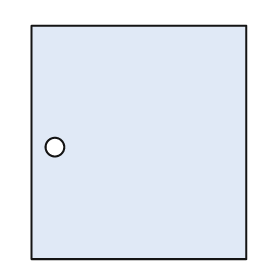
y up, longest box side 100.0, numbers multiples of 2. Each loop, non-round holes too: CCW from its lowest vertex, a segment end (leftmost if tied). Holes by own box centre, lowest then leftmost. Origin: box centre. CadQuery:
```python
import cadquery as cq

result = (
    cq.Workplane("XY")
    .moveTo(-46.0, -50.0)
    .lineTo(46.0, -50.0)
    .lineTo(46.0, 50.0)
    .lineTo(-46.0, 50.0)
    .close()
    .moveTo(-36.0, -2.0)
    .circle(4.0)
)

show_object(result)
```